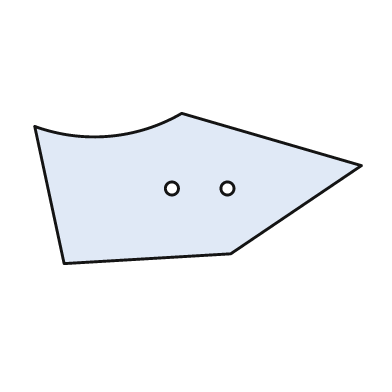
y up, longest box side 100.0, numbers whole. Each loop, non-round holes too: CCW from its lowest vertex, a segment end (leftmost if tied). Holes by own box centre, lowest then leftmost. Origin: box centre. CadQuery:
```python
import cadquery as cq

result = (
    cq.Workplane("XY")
    .moveTo(-41.0, -23.0)
    .lineTo(10.0, -20.0)
    .lineTo(50.0, 7.0)
    .lineTo(-5.0, 23.0)
    .threePointArc((-27.0, 16.0), (-50.0, 19.0))
    .close()
    .moveTo(-8.0, 0.0)
    .circle(2.0)
    .moveTo(9.0, 0.0)
    .circle(2.0)
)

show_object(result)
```